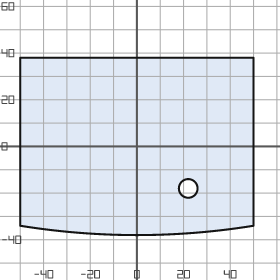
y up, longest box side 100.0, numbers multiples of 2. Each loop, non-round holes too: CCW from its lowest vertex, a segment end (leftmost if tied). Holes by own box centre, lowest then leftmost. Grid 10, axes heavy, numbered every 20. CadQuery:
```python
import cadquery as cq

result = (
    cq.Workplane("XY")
    .moveTo(-50.0, -34.0)
    .threePointArc((0.0, -38.0), (50.0, -34.0))
    .lineTo(50.0, 38.0)
    .lineTo(-50.0, 38.0)
    .close()
    .moveTo(22.0, -18.0)
    .circle(4.0)
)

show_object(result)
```